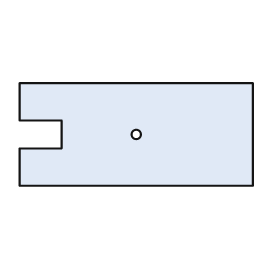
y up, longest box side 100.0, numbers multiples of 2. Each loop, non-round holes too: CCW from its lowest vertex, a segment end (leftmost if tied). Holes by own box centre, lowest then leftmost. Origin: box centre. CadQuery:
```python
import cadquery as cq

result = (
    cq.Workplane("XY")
    .moveTo(-50.0, -22.0)
    .lineTo(50.0, -22.0)
    .lineTo(50.0, 22.0)
    .lineTo(-50.0, 22.0)
    .lineTo(-50.0, 6.0)
    .lineTo(-32.0, 6.0)
    .lineTo(-32.0, -6.0)
    .lineTo(-50.0, -6.0)
    .close()
    .moveTo(0.0, 0.0)
    .circle(2.0)
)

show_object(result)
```